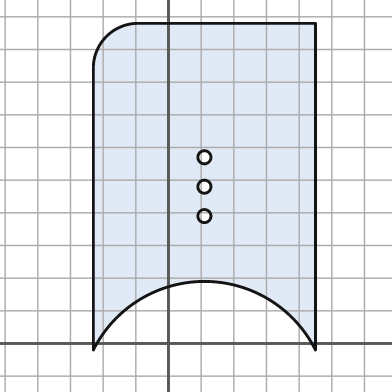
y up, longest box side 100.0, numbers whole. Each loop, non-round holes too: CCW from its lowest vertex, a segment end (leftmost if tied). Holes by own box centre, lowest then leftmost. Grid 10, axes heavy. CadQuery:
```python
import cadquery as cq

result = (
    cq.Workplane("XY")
    .moveTo(-23.0, -2.0)
    .threePointArc((11.0, 19.0), (45.0, -2.0))
    .lineTo(45.0, 98.0)
    .lineTo(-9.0, 98.0)
    .threePointArc((-19.0, 94.0), (-23.0, 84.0))
    .close()
    .moveTo(11.0, 39.0)
    .circle(2.0)
    .moveTo(11.0, 48.0)
    .circle(2.0)
    .moveTo(11.0, 57.0)
    .circle(2.0)
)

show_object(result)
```